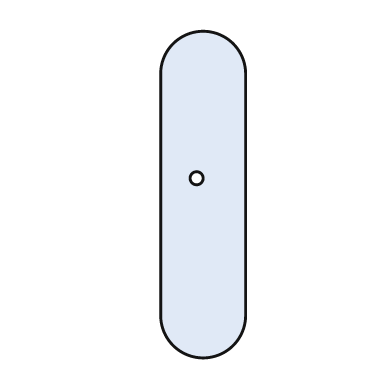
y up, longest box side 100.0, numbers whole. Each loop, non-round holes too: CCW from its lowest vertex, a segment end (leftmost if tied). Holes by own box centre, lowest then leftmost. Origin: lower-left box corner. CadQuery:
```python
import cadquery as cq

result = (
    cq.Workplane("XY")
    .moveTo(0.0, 13.0)
    .threePointArc((13.0, 0.0), (26.0, 13.0))
    .lineTo(26.0, 87.0)
    .threePointArc((13.0, 100.0), (0.0, 87.0))
    .close()
    .moveTo(11.0, 55.0)
    .circle(2.0)
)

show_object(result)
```